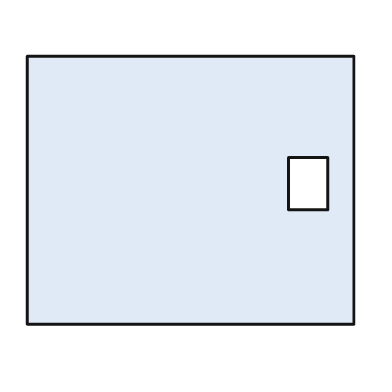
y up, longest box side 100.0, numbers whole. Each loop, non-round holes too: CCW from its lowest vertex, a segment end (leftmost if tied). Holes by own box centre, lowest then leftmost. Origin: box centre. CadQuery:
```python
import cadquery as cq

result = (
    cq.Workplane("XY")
    .moveTo(-50.0, -41.0)
    .lineTo(50.0, -41.0)
    .lineTo(50.0, 41.0)
    .lineTo(-50.0, 41.0)
    .close()
    .moveTo(30.0, -6.0)
    .lineTo(42.0, -6.0)
    .lineTo(42.0, 10.0)
    .lineTo(30.0, 10.0)
    .close()
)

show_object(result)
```